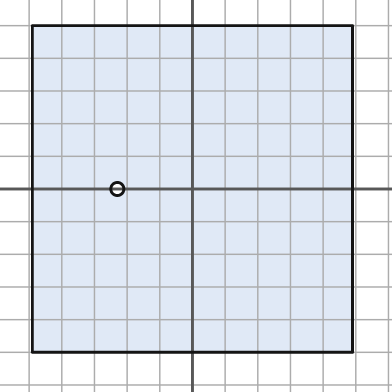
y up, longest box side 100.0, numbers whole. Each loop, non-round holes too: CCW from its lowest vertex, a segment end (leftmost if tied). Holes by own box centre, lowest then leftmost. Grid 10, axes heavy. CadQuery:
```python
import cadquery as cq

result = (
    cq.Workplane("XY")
    .moveTo(-49.0, -50.0)
    .lineTo(49.0, -50.0)
    .lineTo(49.0, 50.0)
    .lineTo(-49.0, 50.0)
    .close()
    .moveTo(-23.0, 0.0)
    .circle(2.0)
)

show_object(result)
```